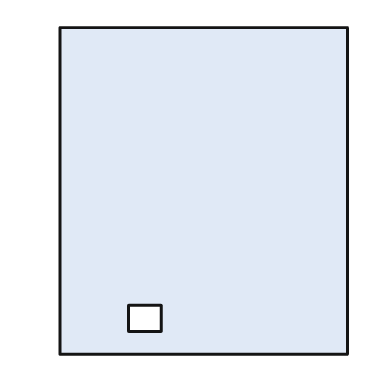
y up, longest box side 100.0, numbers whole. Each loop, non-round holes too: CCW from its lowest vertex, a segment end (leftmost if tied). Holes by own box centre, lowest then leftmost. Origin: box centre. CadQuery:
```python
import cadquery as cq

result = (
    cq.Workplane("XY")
    .moveTo(-44.0, -50.0)
    .lineTo(44.0, -50.0)
    .lineTo(44.0, 50.0)
    .lineTo(-44.0, 50.0)
    .close()
    .moveTo(-23.0, -43.0)
    .lineTo(-13.0, -43.0)
    .lineTo(-13.0, -35.0)
    .lineTo(-23.0, -35.0)
    .close()
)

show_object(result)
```